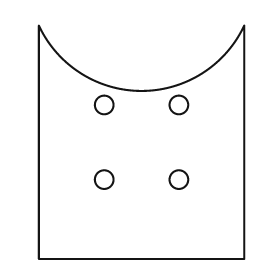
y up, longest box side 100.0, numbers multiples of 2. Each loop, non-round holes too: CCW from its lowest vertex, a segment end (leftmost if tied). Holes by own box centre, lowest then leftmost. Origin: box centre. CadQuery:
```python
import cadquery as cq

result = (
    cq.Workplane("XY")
    .moveTo(-44.0, -50.0)
    .lineTo(44.0, -50.0)
    .lineTo(44.0, 50.0)
    .threePointArc((0.0, 22.0), (-44.0, 50.0))
    .close()
    .moveTo(-16.0, -16.0)
    .circle(4.0)
    .moveTo(16.0, -16.0)
    .circle(4.0)
    .moveTo(-16.0, 16.0)
    .circle(4.0)
    .moveTo(16.0, 16.0)
    .circle(4.0)
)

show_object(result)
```